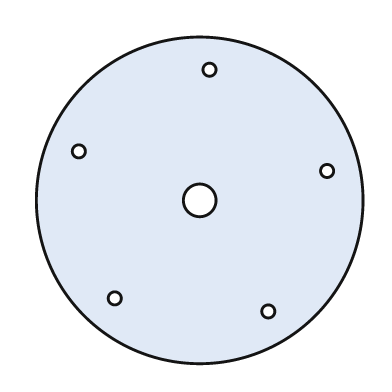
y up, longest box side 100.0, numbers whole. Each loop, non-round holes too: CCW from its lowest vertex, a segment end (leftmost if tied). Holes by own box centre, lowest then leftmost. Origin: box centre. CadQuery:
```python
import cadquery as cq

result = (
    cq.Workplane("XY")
    .moveTo(0.0, 0.0)
    .circle(50.0)
    .moveTo(21.0, -34.0)
    .circle(2.0)
    .moveTo(-26.0, -30.0)
    .circle(2.0)
    .moveTo(0.0, 0.0)
    .circle(5.0)
    .moveTo(39.0, 9.0)
    .circle(2.0)
    .moveTo(-37.0, 15.0)
    .circle(2.0)
    .moveTo(3.0, 40.0)
    .circle(2.0)
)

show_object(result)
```